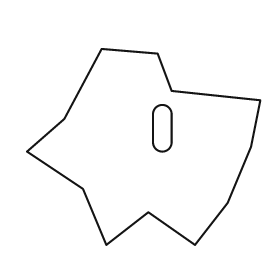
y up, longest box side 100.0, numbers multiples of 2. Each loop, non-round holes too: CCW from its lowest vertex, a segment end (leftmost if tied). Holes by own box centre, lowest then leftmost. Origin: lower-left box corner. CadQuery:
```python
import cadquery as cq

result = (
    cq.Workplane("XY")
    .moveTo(34.0, 0.0)
    .lineTo(52.0, 14.0)
    .lineTo(72.0, 0.0)
    .lineTo(86.0, 18.0)
    .lineTo(96.0, 42.0)
    .lineTo(100.0, 62.0)
    .lineTo(62.0, 66.0)
    .lineTo(56.0, 82.0)
    .lineTo(32.0, 84.0)
    .lineTo(16.0, 54.0)
    .lineTo(0.0, 40.0)
    .lineTo(24.0, 24.0)
    .close()
    .moveTo(54.0, 44.0)
    .threePointArc((58.0, 40.0), (62.0, 44.0))
    .lineTo(62.0, 56.0)
    .threePointArc((58.0, 60.0), (54.0, 56.0))
    .close()
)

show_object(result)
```